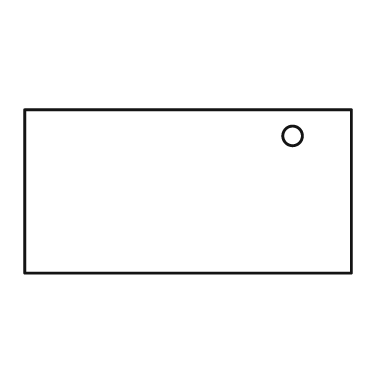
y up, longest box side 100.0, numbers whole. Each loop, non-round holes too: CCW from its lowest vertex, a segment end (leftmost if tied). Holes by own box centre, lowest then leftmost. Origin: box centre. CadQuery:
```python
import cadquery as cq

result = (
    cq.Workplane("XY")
    .moveTo(-50.0, -25.0)
    .lineTo(50.0, -25.0)
    .lineTo(50.0, 25.0)
    .lineTo(-50.0, 25.0)
    .close()
    .moveTo(32.0, 17.0)
    .circle(3.0)
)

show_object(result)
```